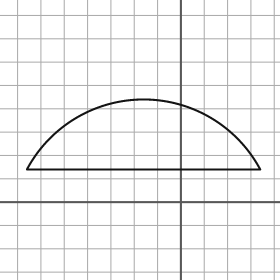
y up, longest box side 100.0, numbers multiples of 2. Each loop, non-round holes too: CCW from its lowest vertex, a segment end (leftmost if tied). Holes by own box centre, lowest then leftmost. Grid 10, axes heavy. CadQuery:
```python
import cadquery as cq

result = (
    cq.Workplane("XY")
    .moveTo(-66.0, 14.0)
    .lineTo(34.0, 14.0)
    .threePointArc((-16.0, 44.0), (-66.0, 14.0))
    .close()
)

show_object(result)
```